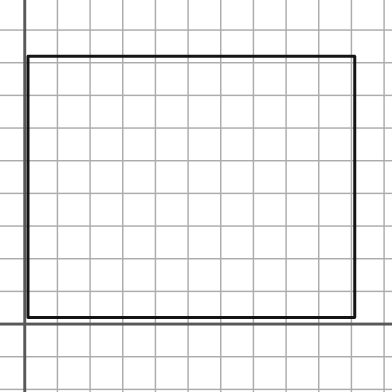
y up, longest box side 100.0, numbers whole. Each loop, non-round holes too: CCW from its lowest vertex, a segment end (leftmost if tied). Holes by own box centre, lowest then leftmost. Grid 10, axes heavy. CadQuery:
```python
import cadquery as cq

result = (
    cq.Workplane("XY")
    .moveTo(1.0, 2.0)
    .lineTo(101.0, 2.0)
    .lineTo(101.0, 82.0)
    .lineTo(1.0, 82.0)
    .close()
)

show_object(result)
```